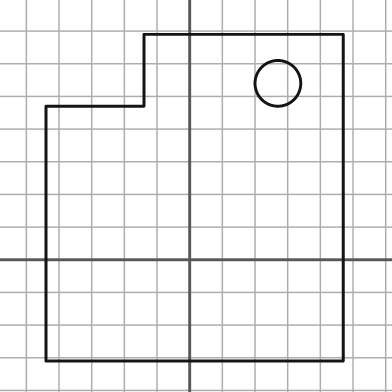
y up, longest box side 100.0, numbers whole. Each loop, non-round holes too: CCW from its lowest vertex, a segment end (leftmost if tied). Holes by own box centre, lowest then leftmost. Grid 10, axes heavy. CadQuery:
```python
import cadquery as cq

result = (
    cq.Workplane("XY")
    .moveTo(-44.0, -31.0)
    .lineTo(47.0, -31.0)
    .lineTo(47.0, 69.0)
    .lineTo(-14.0, 69.0)
    .lineTo(-14.0, 47.0)
    .lineTo(-44.0, 47.0)
    .close()
    .moveTo(27.0, 54.0)
    .circle(7.0)
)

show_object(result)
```